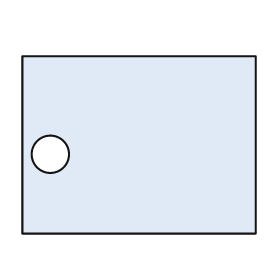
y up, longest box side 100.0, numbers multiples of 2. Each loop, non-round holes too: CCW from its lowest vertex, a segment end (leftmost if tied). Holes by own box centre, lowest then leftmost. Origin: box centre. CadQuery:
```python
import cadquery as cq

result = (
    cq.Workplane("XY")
    .moveTo(-50.0, -38.0)
    .lineTo(50.0, -38.0)
    .lineTo(50.0, 38.0)
    .lineTo(-50.0, 38.0)
    .close()
    .moveTo(-38.0, -4.0)
    .circle(8.0)
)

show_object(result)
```